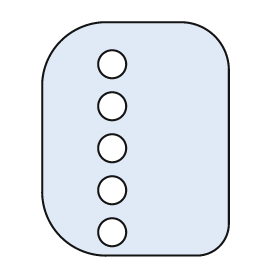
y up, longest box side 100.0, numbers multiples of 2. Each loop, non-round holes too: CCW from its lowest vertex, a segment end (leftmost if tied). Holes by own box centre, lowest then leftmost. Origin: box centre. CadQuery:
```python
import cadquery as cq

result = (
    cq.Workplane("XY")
    .moveTo(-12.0, -50.0)
    .lineTo(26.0, -50.0)
    .threePointArc((36.0, -46.0), (40.0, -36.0))
    .lineTo(40.0, 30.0)
    .threePointArc((34.0, 44.0), (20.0, 50.0))
    .lineTo(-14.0, 50.0)
    .threePointArc((-32.0, 42.0), (-40.0, 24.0))
    .lineTo(-40.0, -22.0)
    .threePointArc((-32.0, -42.0), (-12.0, -50.0))
    .close()
    .moveTo(-10.0, -40.0)
    .circle(6.0)
    .moveTo(-10.0, -22.0)
    .circle(6.0)
    .moveTo(-10.0, -4.0)
    .circle(6.0)
    .moveTo(-10.0, 14.0)
    .circle(6.0)
    .moveTo(-10.0, 32.0)
    .circle(6.0)
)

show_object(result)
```